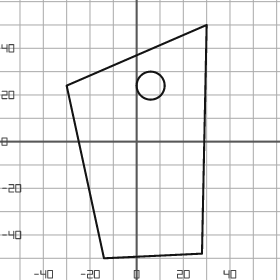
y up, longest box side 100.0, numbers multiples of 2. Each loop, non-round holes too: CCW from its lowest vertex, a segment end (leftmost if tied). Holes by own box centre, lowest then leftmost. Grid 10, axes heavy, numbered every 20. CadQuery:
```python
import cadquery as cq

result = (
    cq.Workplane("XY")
    .moveTo(-14.0, -50.0)
    .lineTo(28.0, -48.0)
    .lineTo(30.0, 50.0)
    .lineTo(-30.0, 24.0)
    .close()
    .moveTo(6.0, 24.0)
    .circle(6.0)
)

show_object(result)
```